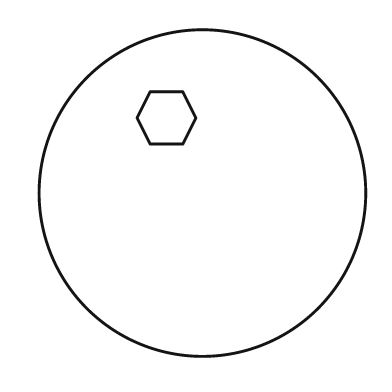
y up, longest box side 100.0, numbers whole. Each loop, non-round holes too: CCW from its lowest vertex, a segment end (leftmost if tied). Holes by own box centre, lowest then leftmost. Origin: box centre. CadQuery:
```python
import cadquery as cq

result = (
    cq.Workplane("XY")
    .moveTo(0.0, 0.0)
    .circle(50.0)
    .moveTo(-16.0, 15.0)
    .lineTo(-6.0, 15.0)
    .lineTo(-2.0, 23.0)
    .lineTo(-6.0, 31.0)
    .lineTo(-16.0, 31.0)
    .lineTo(-20.0, 23.0)
    .close()
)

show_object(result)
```